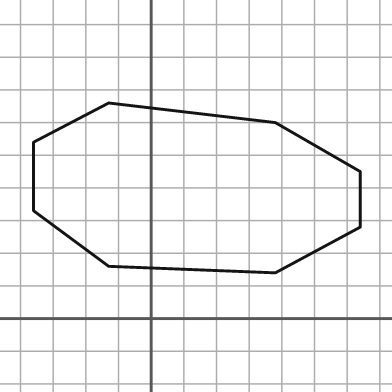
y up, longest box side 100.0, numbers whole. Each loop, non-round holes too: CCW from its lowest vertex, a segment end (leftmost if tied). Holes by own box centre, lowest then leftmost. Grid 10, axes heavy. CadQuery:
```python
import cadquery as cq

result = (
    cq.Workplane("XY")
    .moveTo(38.0, 14.0)
    .lineTo(64.0, 28.0)
    .lineTo(64.0, 45.0)
    .lineTo(38.0, 60.0)
    .lineTo(-13.0, 66.0)
    .lineTo(-36.0, 54.0)
    .lineTo(-36.0, 33.0)
    .lineTo(-13.0, 16.0)
    .close()
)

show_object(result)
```